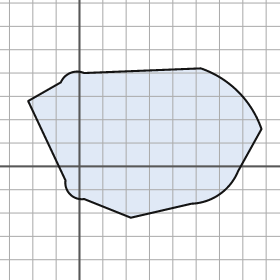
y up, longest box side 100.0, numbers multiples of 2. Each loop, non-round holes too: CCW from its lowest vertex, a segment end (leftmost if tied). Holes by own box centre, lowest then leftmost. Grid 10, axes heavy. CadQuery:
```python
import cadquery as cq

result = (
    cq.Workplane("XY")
    .moveTo(22.0, -22.0)
    .lineTo(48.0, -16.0)
    .threePointArc((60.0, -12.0), (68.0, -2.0))
    .lineTo(78.0, 16.0)
    .threePointArc((68.0, 32.0), (52.0, 42.0))
    .lineTo(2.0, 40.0)
    .threePointArc((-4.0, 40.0), (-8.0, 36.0))
    .lineTo(-22.0, 28.0)
    .lineTo(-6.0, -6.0)
    .threePointArc((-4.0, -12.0), (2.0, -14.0))
    .close()
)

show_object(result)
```